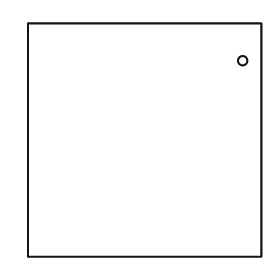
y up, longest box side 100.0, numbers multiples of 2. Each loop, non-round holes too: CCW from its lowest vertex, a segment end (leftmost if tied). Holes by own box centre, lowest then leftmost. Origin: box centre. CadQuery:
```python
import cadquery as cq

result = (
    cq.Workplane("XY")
    .moveTo(-50.0, -50.0)
    .lineTo(50.0, -50.0)
    .lineTo(50.0, 50.0)
    .lineTo(-50.0, 50.0)
    .close()
    .moveTo(42.0, 34.0)
    .circle(2.0)
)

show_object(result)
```